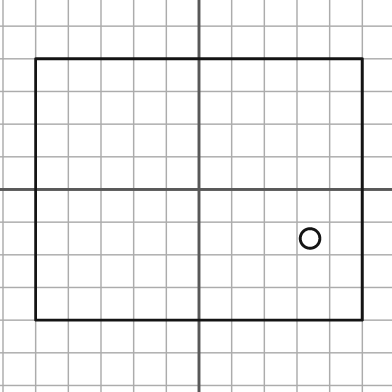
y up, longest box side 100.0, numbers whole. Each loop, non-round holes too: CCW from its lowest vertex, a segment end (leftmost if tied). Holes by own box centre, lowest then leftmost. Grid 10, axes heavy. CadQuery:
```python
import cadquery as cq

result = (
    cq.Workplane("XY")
    .moveTo(-50.0, -40.0)
    .lineTo(50.0, -40.0)
    .lineTo(50.0, 40.0)
    .lineTo(-50.0, 40.0)
    .close()
    .moveTo(34.0, -15.0)
    .circle(3.0)
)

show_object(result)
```